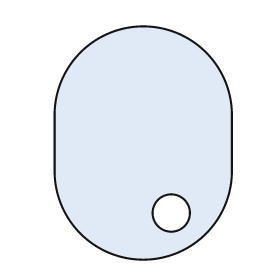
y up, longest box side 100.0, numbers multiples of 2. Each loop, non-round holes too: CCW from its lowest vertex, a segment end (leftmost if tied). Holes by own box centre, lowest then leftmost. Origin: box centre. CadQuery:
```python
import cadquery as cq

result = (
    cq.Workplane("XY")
    .moveTo(-38.0, -12.0)
    .threePointArc((0.0, -50.0), (38.0, -12.0))
    .lineTo(38.0, 12.0)
    .threePointArc((0.0, 50.0), (-38.0, 12.0))
    .close()
    .moveTo(12.0, -30.0)
    .circle(8.0)
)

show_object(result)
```